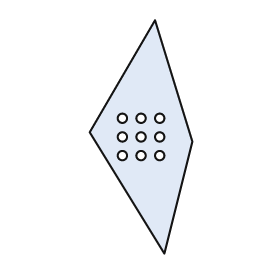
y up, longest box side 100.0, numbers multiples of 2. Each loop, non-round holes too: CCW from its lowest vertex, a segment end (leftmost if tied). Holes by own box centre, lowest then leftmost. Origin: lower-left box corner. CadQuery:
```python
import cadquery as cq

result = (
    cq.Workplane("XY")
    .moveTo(32.0, 0.0)
    .lineTo(44.0, 48.0)
    .lineTo(28.0, 100.0)
    .lineTo(0.0, 52.0)
    .close()
    .moveTo(14.0, 42.0)
    .circle(2.0)
    .moveTo(22.0, 42.0)
    .circle(2.0)
    .moveTo(30.0, 42.0)
    .circle(2.0)
    .moveTo(14.0, 50.0)
    .circle(2.0)
    .moveTo(22.0, 50.0)
    .circle(2.0)
    .moveTo(30.0, 50.0)
    .circle(2.0)
    .moveTo(14.0, 58.0)
    .circle(2.0)
    .moveTo(22.0, 58.0)
    .circle(2.0)
    .moveTo(30.0, 58.0)
    .circle(2.0)
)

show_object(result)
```